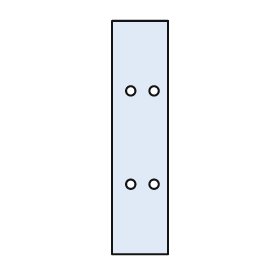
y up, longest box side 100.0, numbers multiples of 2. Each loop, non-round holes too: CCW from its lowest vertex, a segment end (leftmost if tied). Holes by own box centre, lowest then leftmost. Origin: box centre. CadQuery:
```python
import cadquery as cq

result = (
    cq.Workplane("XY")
    .moveTo(-12.0, -50.0)
    .lineTo(12.0, -50.0)
    .lineTo(12.0, 50.0)
    .lineTo(-12.0, 50.0)
    .close()
    .moveTo(-4.0, -20.0)
    .circle(2.0)
    .moveTo(6.0, -20.0)
    .circle(2.0)
    .moveTo(-4.0, 20.0)
    .circle(2.0)
    .moveTo(6.0, 20.0)
    .circle(2.0)
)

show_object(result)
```